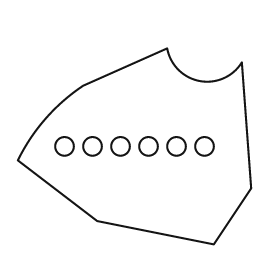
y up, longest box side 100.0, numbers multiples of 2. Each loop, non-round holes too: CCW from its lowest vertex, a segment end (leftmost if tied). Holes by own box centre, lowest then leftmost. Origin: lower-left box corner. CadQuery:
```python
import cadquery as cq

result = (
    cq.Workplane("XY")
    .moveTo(84.0, 0.0)
    .lineTo(100.0, 24.0)
    .lineTo(96.0, 78.0)
    .threePointArc((78.0, 70.0), (64.0, 84.0))
    .lineTo(28.0, 68.0)
    .threePointArc((12.0, 54.0), (0.0, 36.0))
    .lineTo(34.0, 10.0)
    .close()
    .moveTo(20.0, 42.0)
    .circle(4.0)
    .moveTo(32.0, 42.0)
    .circle(4.0)
    .moveTo(44.0, 42.0)
    .circle(4.0)
    .moveTo(56.0, 42.0)
    .circle(4.0)
    .moveTo(68.0, 42.0)
    .circle(4.0)
    .moveTo(80.0, 42.0)
    .circle(4.0)
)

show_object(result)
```